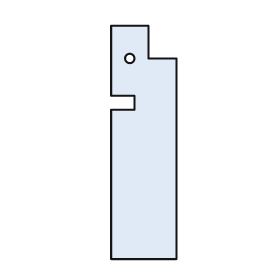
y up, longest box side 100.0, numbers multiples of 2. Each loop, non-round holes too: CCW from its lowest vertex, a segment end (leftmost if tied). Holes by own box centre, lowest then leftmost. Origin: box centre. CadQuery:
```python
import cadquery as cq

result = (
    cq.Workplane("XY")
    .moveTo(-14.0, -50.0)
    .lineTo(14.0, -50.0)
    .lineTo(14.0, 36.0)
    .lineTo(2.0, 36.0)
    .lineTo(2.0, 50.0)
    .lineTo(-14.0, 50.0)
    .lineTo(-14.0, 20.0)
    .lineTo(-4.0, 20.0)
    .lineTo(-4.0, 14.0)
    .lineTo(-14.0, 14.0)
    .close()
    .moveTo(-6.0, 36.0)
    .circle(2.0)
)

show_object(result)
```